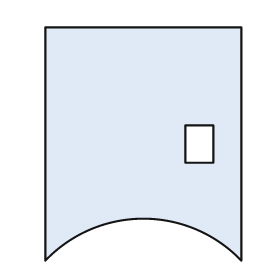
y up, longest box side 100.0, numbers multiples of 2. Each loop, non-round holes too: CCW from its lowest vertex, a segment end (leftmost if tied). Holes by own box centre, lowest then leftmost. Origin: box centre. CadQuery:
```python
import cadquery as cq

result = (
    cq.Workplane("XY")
    .moveTo(-42.0, -50.0)
    .threePointArc((0.0, -32.0), (42.0, -50.0))
    .lineTo(42.0, 50.0)
    .lineTo(-42.0, 50.0)
    .close()
    .moveTo(18.0, -8.0)
    .lineTo(30.0, -8.0)
    .lineTo(30.0, 8.0)
    .lineTo(18.0, 8.0)
    .close()
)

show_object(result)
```